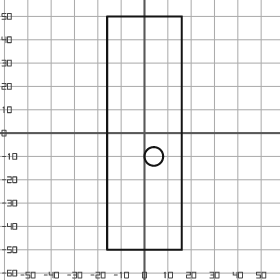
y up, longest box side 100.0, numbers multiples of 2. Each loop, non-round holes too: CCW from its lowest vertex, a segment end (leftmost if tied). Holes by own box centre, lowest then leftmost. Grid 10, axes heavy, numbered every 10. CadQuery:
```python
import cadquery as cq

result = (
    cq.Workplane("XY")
    .moveTo(-16.0, -50.0)
    .lineTo(16.0, -50.0)
    .lineTo(16.0, 50.0)
    .lineTo(-16.0, 50.0)
    .close()
    .moveTo(4.0, -10.0)
    .circle(4.0)
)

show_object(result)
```